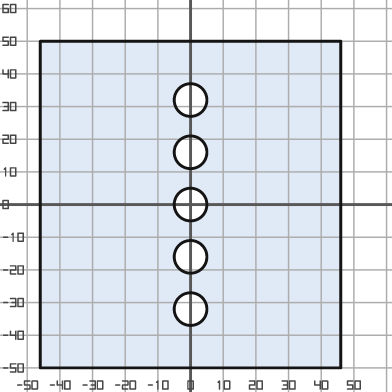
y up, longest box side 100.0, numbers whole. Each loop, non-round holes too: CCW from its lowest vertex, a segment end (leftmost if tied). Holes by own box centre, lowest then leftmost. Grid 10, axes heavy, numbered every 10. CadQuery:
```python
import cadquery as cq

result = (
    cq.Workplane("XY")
    .moveTo(-46.0, -50.0)
    .lineTo(46.0, -50.0)
    .lineTo(46.0, 50.0)
    .lineTo(-46.0, 50.0)
    .close()
    .moveTo(0.0, -32.0)
    .circle(5.0)
    .moveTo(0.0, -16.0)
    .circle(5.0)
    .moveTo(0.0, 0.0)
    .circle(5.0)
    .moveTo(0.0, 16.0)
    .circle(5.0)
    .moveTo(0.0, 32.0)
    .circle(5.0)
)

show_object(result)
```